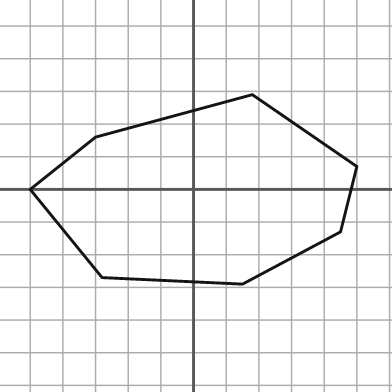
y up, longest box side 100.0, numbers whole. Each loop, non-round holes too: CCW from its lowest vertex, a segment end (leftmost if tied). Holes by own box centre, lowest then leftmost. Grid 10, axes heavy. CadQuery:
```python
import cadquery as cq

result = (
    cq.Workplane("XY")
    .moveTo(15.0, -29.0)
    .lineTo(45.0, -13.0)
    .lineTo(50.0, 7.0)
    .lineTo(18.0, 29.0)
    .lineTo(-30.0, 16.0)
    .lineTo(-50.0, 0.0)
    .lineTo(-28.0, -27.0)
    .close()
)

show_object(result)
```